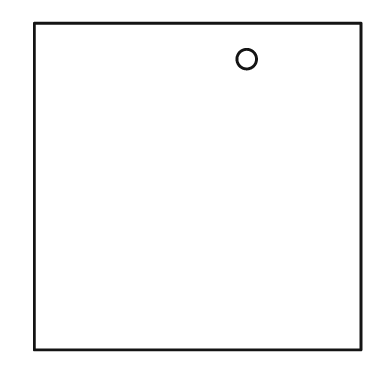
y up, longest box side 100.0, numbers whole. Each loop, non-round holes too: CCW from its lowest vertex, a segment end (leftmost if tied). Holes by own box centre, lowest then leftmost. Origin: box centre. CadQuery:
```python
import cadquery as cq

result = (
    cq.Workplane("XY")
    .moveTo(-50.0, -50.0)
    .lineTo(50.0, -50.0)
    .lineTo(50.0, 50.0)
    .lineTo(-50.0, 50.0)
    .close()
    .moveTo(15.0, 39.0)
    .circle(3.0)
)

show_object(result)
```